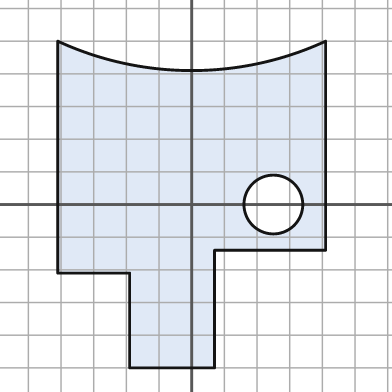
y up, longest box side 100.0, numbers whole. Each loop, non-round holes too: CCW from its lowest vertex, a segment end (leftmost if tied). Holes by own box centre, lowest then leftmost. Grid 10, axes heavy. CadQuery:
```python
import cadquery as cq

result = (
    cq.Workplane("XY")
    .moveTo(-19.0, -50.0)
    .lineTo(7.0, -50.0)
    .lineTo(7.0, -14.0)
    .lineTo(41.0, -14.0)
    .lineTo(41.0, 50.0)
    .threePointArc((0.0, 41.0), (-41.0, 50.0))
    .lineTo(-41.0, -21.0)
    .lineTo(-19.0, -21.0)
    .close()
    .moveTo(25.0, 0.0)
    .circle(9.0)
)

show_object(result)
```